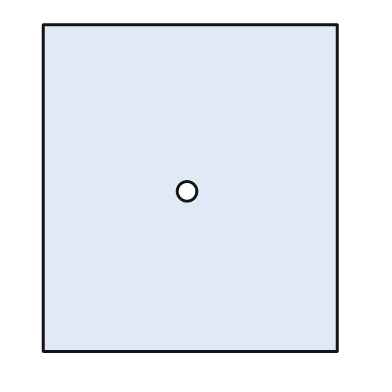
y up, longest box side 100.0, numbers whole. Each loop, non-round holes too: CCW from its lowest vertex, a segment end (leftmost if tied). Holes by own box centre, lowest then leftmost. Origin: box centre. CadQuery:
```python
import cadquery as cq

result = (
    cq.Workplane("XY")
    .moveTo(-45.0, -50.0)
    .lineTo(45.0, -50.0)
    .lineTo(45.0, 50.0)
    .lineTo(-45.0, 50.0)
    .close()
    .moveTo(-1.0, -1.0)
    .circle(3.0)
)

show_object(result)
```